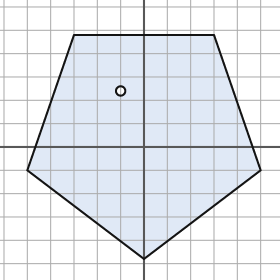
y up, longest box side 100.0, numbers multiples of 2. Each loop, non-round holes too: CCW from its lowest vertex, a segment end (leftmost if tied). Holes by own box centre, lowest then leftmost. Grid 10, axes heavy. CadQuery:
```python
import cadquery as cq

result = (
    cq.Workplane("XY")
    .moveTo(0.0, -48.0)
    .lineTo(50.0, -10.0)
    .lineTo(30.0, 48.0)
    .lineTo(-30.0, 48.0)
    .lineTo(-50.0, -10.0)
    .close()
    .moveTo(-10.0, 24.0)
    .circle(2.0)
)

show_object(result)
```